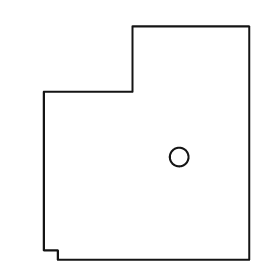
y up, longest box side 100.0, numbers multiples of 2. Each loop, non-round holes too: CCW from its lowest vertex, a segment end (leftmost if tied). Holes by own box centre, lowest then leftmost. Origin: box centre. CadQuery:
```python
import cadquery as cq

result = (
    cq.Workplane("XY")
    .moveTo(-38.0, -50.0)
    .lineTo(44.0, -50.0)
    .lineTo(44.0, 50.0)
    .lineTo(-6.0, 50.0)
    .lineTo(-6.0, 22.0)
    .lineTo(-44.0, 22.0)
    .lineTo(-44.0, -46.0)
    .lineTo(-38.0, -46.0)
    .close()
    .moveTo(14.0, -6.0)
    .circle(4.0)
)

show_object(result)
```